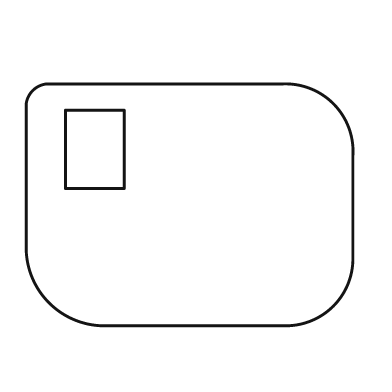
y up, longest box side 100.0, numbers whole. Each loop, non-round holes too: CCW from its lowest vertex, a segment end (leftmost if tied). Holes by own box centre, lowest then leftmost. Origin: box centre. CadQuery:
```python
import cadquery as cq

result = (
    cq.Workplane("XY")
    .moveTo(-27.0, -37.0)
    .lineTo(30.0, -37.0)
    .threePointArc((44.0, -31.0), (50.0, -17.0))
    .lineTo(50.0, 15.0)
    .threePointArc((44.0, 31.0), (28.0, 37.0))
    .lineTo(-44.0, 37.0)
    .threePointArc((-48.0, 35.0), (-50.0, 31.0))
    .lineTo(-50.0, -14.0)
    .threePointArc((-43.0, -30.0), (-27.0, -37.0))
    .close()
    .moveTo(-38.0, 5.0)
    .lineTo(-20.0, 5.0)
    .lineTo(-20.0, 29.0)
    .lineTo(-38.0, 29.0)
    .close()
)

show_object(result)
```